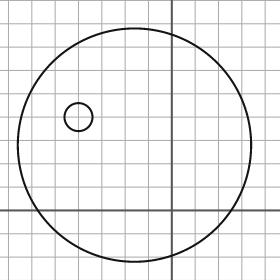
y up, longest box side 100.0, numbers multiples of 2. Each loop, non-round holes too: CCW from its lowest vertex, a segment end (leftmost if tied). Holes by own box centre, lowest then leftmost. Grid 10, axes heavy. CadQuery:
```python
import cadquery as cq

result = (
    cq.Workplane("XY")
    .moveTo(-16.0, 28.0)
    .circle(50.0)
    .moveTo(-40.0, 40.0)
    .circle(6.0)
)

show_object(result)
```